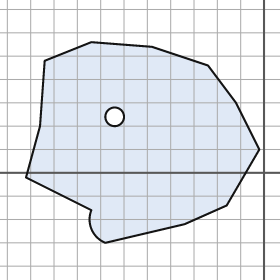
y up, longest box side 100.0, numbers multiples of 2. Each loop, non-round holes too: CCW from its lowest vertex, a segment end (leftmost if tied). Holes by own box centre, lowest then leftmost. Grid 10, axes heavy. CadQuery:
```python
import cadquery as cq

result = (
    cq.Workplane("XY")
    .moveTo(-68.0, -30.0)
    .lineTo(-34.0, -22.0)
    .lineTo(-16.0, -14.0)
    .lineTo(-2.0, 10.0)
    .lineTo(-12.0, 30.0)
    .lineTo(-24.0, 46.0)
    .lineTo(-48.0, 54.0)
    .lineTo(-74.0, 56.0)
    .lineTo(-94.0, 48.0)
    .lineTo(-96.0, 20.0)
    .lineTo(-102.0, -2.0)
    .lineTo(-74.0, -16.0)
    .threePointArc((-74.0, -24.0), (-68.0, -30.0))
    .close()
    .moveTo(-64.0, 24.0)
    .circle(4.0)
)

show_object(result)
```